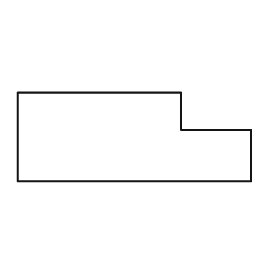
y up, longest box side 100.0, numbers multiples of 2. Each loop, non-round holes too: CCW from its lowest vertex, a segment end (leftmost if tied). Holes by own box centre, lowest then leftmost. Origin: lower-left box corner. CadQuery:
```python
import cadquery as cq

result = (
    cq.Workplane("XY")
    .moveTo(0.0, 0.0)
    .lineTo(100.0, 0.0)
    .lineTo(100.0, 22.0)
    .lineTo(70.0, 22.0)
    .lineTo(70.0, 38.0)
    .lineTo(0.0, 38.0)
    .close()
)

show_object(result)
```